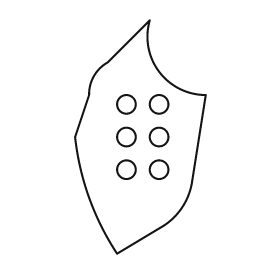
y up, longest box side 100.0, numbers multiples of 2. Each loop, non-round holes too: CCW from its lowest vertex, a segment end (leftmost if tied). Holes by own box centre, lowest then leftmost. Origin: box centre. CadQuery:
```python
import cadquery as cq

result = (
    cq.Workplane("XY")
    .moveTo(-10.0, -50.0)
    .lineTo(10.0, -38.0)
    .threePointArc((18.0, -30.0), (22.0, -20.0))
    .lineTo(28.0, 18.0)
    .threePointArc((8.0, 28.0), (4.0, 50.0))
    .lineTo(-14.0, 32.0)
    .threePointArc((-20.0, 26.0), (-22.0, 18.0))
    .lineTo(-28.0, 0.0)
    .threePointArc((-22.0, -26.0), (-10.0, -50.0))
    .close()
    .moveTo(-6.0, -14.0)
    .circle(4.0)
    .moveTo(8.0, -14.0)
    .circle(4.0)
    .moveTo(-6.0, 0.0)
    .circle(4.0)
    .moveTo(8.0, 0.0)
    .circle(4.0)
    .moveTo(-6.0, 14.0)
    .circle(4.0)
    .moveTo(8.0, 14.0)
    .circle(4.0)
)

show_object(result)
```